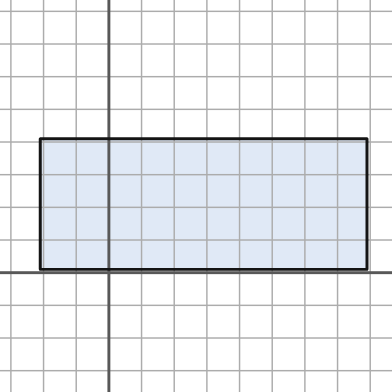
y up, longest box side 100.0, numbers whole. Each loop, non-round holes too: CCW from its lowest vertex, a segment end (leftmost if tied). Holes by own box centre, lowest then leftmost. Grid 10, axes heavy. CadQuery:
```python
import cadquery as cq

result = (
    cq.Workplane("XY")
    .moveTo(-21.0, 1.0)
    .lineTo(79.0, 1.0)
    .lineTo(79.0, 41.0)
    .lineTo(-21.0, 41.0)
    .close()
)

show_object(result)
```